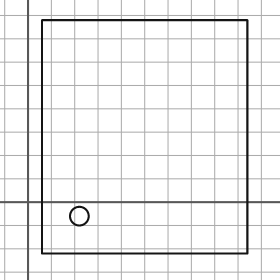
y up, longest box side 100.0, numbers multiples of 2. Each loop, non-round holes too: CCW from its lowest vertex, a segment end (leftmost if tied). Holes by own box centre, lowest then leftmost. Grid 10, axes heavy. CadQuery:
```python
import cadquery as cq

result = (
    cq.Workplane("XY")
    .moveTo(6.0, -22.0)
    .lineTo(94.0, -22.0)
    .lineTo(94.0, 78.0)
    .lineTo(6.0, 78.0)
    .close()
    .moveTo(22.0, -6.0)
    .circle(4.0)
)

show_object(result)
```